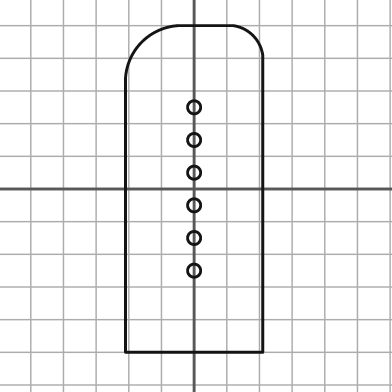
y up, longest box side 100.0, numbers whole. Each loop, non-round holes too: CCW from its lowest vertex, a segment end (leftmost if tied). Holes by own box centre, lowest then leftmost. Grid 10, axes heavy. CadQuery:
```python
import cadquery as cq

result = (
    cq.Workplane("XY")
    .moveTo(-21.0, -50.0)
    .lineTo(21.0, -50.0)
    .lineTo(21.0, 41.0)
    .threePointArc((18.0, 47.0), (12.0, 50.0))
    .lineTo(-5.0, 50.0)
    .threePointArc((-16.0, 45.0), (-21.0, 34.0))
    .close()
    .moveTo(0.0, -25.0)
    .circle(2.0)
    .moveTo(0.0, -15.0)
    .circle(2.0)
    .moveTo(0.0, -5.0)
    .circle(2.0)
    .moveTo(0.0, 5.0)
    .circle(2.0)
    .moveTo(0.0, 15.0)
    .circle(2.0)
    .moveTo(0.0, 25.0)
    .circle(2.0)
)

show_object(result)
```